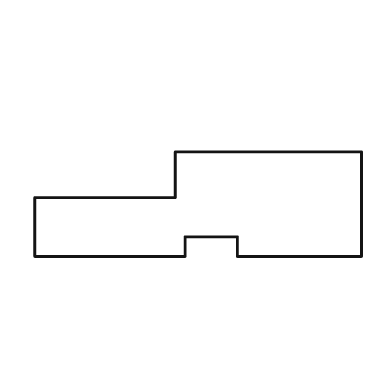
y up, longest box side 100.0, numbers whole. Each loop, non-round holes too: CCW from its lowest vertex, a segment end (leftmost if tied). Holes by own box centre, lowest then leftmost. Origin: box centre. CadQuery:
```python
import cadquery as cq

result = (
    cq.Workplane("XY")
    .moveTo(-50.0, -16.0)
    .lineTo(-4.0, -16.0)
    .lineTo(-4.0, -10.0)
    .lineTo(12.0, -10.0)
    .lineTo(12.0, -16.0)
    .lineTo(50.0, -16.0)
    .lineTo(50.0, 16.0)
    .lineTo(-7.0, 16.0)
    .lineTo(-7.0, 2.0)
    .lineTo(-50.0, 2.0)
    .close()
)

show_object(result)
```